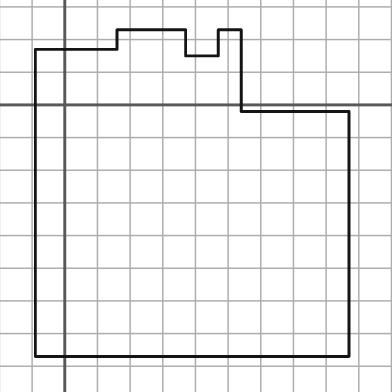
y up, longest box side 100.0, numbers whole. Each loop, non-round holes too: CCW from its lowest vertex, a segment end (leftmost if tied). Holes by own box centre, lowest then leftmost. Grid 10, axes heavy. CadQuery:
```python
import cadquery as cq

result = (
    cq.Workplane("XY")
    .moveTo(-9.0, -77.0)
    .lineTo(87.0, -77.0)
    .lineTo(87.0, -2.0)
    .lineTo(54.0, -2.0)
    .lineTo(54.0, 23.0)
    .lineTo(47.0, 23.0)
    .lineTo(47.0, 15.0)
    .lineTo(37.0, 15.0)
    .lineTo(37.0, 23.0)
    .lineTo(16.0, 23.0)
    .lineTo(16.0, 17.0)
    .lineTo(-9.0, 17.0)
    .close()
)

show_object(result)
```